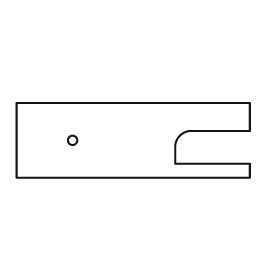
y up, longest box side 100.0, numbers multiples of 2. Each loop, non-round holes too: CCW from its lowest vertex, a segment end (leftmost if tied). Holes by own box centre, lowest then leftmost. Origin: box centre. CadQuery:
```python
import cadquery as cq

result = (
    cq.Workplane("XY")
    .moveTo(-50.0, -16.0)
    .lineTo(50.0, -16.0)
    .lineTo(50.0, -10.0)
    .lineTo(18.0, -10.0)
    .lineTo(18.0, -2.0)
    .threePointArc((20.0, 2.0), (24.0, 4.0))
    .lineTo(50.0, 4.0)
    .lineTo(50.0, 16.0)
    .lineTo(-50.0, 16.0)
    .close()
    .moveTo(-26.0, 0.0)
    .circle(2.0)
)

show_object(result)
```